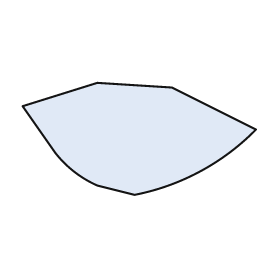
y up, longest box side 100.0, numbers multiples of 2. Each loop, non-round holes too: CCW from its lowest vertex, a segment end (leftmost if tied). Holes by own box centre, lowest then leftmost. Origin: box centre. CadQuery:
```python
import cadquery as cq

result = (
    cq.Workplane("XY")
    .moveTo(-2.0, -24.0)
    .threePointArc((26.0, -14.0), (50.0, 4.0))
    .lineTo(14.0, 22.0)
    .lineTo(-18.0, 24.0)
    .lineTo(-50.0, 14.0)
    .lineTo(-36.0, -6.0)
    .threePointArc((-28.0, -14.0), (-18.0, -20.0))
    .close()
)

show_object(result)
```